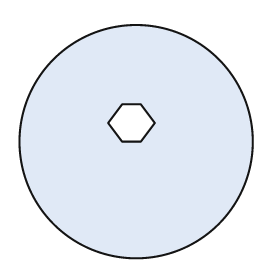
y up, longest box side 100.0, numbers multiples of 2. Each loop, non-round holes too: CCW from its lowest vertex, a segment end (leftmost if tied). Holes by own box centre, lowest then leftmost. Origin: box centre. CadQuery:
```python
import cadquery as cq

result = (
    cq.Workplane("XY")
    .moveTo(0.0, 0.0)
    .circle(50.0)
    .moveTo(-6.0, 0.0)
    .lineTo(2.0, 0.0)
    .lineTo(8.0, 8.0)
    .lineTo(2.0, 16.0)
    .lineTo(-6.0, 16.0)
    .lineTo(-12.0, 8.0)
    .close()
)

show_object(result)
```